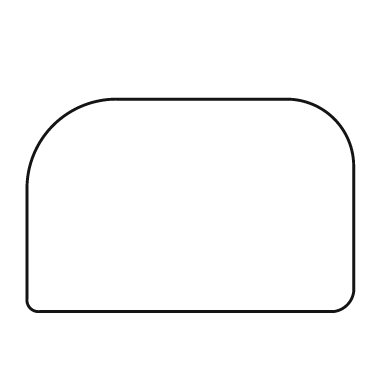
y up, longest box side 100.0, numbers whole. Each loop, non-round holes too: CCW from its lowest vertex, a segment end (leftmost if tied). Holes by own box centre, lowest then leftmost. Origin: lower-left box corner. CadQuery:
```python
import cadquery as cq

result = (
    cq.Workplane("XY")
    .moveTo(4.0, 0.0)
    .lineTo(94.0, 0.0)
    .threePointArc((98.0, 2.0), (100.0, 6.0))
    .lineTo(100.0, 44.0)
    .threePointArc((94.0, 59.0), (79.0, 65.0))
    .lineTo(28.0, 65.0)
    .threePointArc((8.0, 57.0), (0.0, 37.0))
    .lineTo(0.0, 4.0)
    .threePointArc((1.0, 1.0), (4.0, 0.0))
    .close()
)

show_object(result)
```